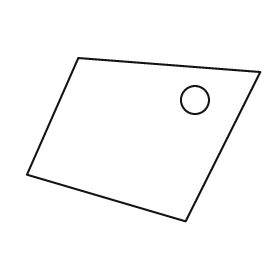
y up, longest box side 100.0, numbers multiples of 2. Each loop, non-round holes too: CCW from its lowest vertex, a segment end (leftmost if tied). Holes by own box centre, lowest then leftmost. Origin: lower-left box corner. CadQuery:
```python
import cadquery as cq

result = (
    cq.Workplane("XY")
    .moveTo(68.0, 0.0)
    .lineTo(100.0, 64.0)
    .lineTo(22.0, 70.0)
    .lineTo(0.0, 20.0)
    .close()
    .moveTo(72.0, 52.0)
    .circle(6.0)
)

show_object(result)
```